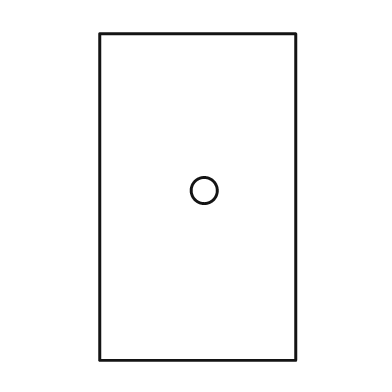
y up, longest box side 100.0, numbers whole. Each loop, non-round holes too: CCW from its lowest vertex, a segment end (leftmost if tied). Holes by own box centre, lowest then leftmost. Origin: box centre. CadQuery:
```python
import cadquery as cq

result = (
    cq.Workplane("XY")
    .moveTo(-30.0, -50.0)
    .lineTo(30.0, -50.0)
    .lineTo(30.0, 50.0)
    .lineTo(-30.0, 50.0)
    .close()
    .moveTo(2.0, 2.0)
    .circle(4.0)
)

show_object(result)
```